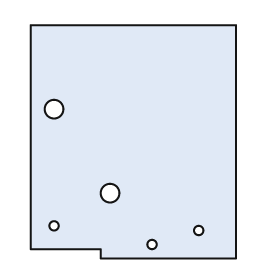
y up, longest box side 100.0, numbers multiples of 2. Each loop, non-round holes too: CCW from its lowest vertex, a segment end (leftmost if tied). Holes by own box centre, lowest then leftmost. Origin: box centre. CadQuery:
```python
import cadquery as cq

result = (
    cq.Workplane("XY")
    .moveTo(-14.0, -50.0)
    .lineTo(44.0, -50.0)
    .lineTo(44.0, 50.0)
    .lineTo(-44.0, 50.0)
    .lineTo(-44.0, -46.0)
    .lineTo(-14.0, -46.0)
    .close()
    .moveTo(8.0, -44.0)
    .circle(2.0)
    .moveTo(28.0, -38.0)
    .circle(2.0)
    .moveTo(-34.0, -36.0)
    .circle(2.0)
    .moveTo(-10.0, -22.0)
    .circle(4.0)
    .moveTo(-34.0, 14.0)
    .circle(4.0)
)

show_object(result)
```